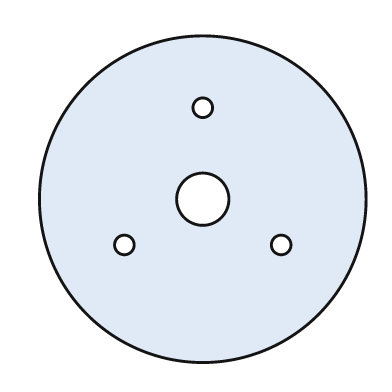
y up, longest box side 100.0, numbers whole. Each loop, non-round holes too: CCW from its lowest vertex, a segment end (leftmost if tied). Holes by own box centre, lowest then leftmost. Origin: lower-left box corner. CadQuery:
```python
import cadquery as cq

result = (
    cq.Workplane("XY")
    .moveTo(50.0, 50.0)
    .circle(50.0)
    .moveTo(26.0, 36.0)
    .circle(3.0)
    .moveTo(74.0, 36.0)
    .circle(3.0)
    .moveTo(50.0, 50.0)
    .circle(8.0)
    .moveTo(50.0, 78.0)
    .circle(3.0)
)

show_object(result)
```